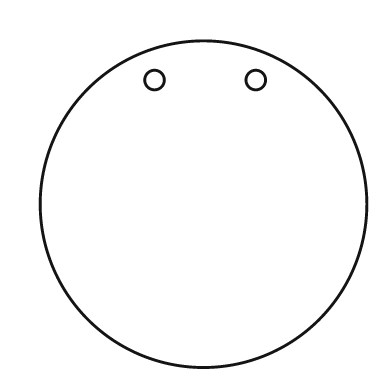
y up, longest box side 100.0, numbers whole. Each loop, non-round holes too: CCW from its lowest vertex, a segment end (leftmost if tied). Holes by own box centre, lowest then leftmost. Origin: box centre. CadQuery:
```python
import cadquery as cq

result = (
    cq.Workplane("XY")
    .moveTo(0.0, 0.0)
    .circle(50.0)
    .moveTo(-15.0, 38.0)
    .circle(3.0)
    .moveTo(16.0, 38.0)
    .circle(3.0)
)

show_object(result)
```